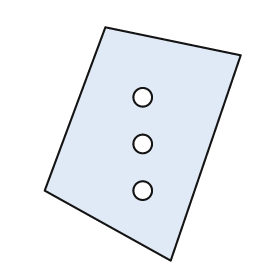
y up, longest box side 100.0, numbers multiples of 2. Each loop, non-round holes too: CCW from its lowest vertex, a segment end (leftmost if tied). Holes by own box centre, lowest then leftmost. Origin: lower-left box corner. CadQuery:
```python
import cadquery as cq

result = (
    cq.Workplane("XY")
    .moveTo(54.0, 0.0)
    .lineTo(84.0, 88.0)
    .lineTo(26.0, 100.0)
    .lineTo(0.0, 30.0)
    .close()
    .moveTo(42.0, 30.0)
    .circle(4.0)
    .moveTo(42.0, 50.0)
    .circle(4.0)
    .moveTo(42.0, 70.0)
    .circle(4.0)
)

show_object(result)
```